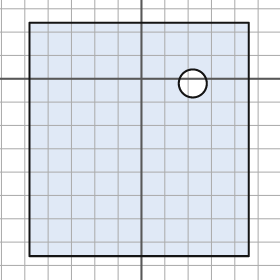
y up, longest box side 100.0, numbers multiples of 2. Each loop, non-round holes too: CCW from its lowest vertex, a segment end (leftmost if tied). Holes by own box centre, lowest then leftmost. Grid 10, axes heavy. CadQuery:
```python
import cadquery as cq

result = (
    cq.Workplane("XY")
    .moveTo(-48.0, -76.0)
    .lineTo(46.0, -76.0)
    .lineTo(46.0, 24.0)
    .lineTo(-48.0, 24.0)
    .close()
    .moveTo(22.0, -2.0)
    .circle(6.0)
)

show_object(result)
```